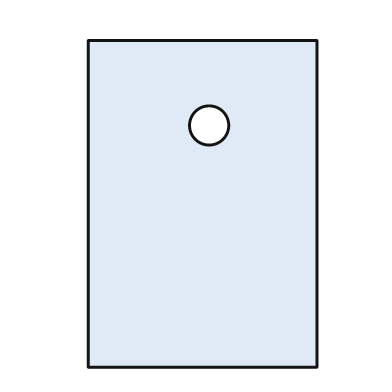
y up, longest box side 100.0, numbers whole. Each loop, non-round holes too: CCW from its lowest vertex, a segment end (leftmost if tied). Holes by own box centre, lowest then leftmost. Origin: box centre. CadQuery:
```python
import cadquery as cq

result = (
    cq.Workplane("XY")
    .moveTo(-35.0, -50.0)
    .lineTo(35.0, -50.0)
    .lineTo(35.0, 50.0)
    .lineTo(-35.0, 50.0)
    .close()
    .moveTo(2.0, 24.0)
    .circle(6.0)
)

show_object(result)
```